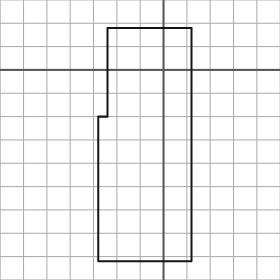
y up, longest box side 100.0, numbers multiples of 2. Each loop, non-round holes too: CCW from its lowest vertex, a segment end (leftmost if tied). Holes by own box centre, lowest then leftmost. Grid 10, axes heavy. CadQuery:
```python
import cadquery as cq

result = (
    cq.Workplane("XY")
    .moveTo(-28.0, -82.0)
    .lineTo(12.0, -82.0)
    .lineTo(12.0, 18.0)
    .lineTo(-24.0, 18.0)
    .lineTo(-24.0, -20.0)
    .lineTo(-28.0, -20.0)
    .close()
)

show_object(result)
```